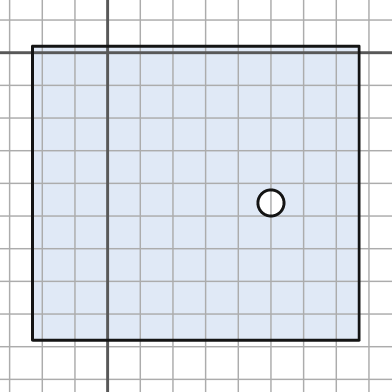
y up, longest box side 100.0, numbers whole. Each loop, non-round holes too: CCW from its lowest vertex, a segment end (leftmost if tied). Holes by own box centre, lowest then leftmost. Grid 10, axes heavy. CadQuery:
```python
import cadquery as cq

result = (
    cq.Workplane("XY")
    .moveTo(-23.0, -88.0)
    .lineTo(77.0, -88.0)
    .lineTo(77.0, 2.0)
    .lineTo(-23.0, 2.0)
    .close()
    .moveTo(50.0, -46.0)
    .circle(4.0)
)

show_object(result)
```